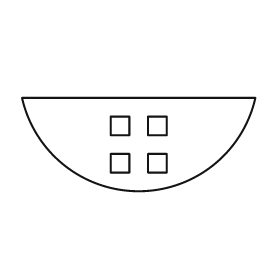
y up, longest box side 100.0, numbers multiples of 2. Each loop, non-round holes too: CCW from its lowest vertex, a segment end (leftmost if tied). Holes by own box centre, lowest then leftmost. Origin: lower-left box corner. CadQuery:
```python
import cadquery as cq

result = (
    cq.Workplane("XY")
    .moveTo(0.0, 40.0)
    .threePointArc((50.0, 0.0), (100.0, 40.0))
    .close()
    .moveTo(38.0, 8.0)
    .lineTo(46.0, 8.0)
    .lineTo(46.0, 16.0)
    .lineTo(38.0, 16.0)
    .close()
    .moveTo(54.0, 8.0)
    .lineTo(62.0, 8.0)
    .lineTo(62.0, 16.0)
    .lineTo(54.0, 16.0)
    .close()
    .moveTo(38.0, 24.0)
    .lineTo(46.0, 24.0)
    .lineTo(46.0, 32.0)
    .lineTo(38.0, 32.0)
    .close()
    .moveTo(54.0, 24.0)
    .lineTo(62.0, 24.0)
    .lineTo(62.0, 32.0)
    .lineTo(54.0, 32.0)
    .close()
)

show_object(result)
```